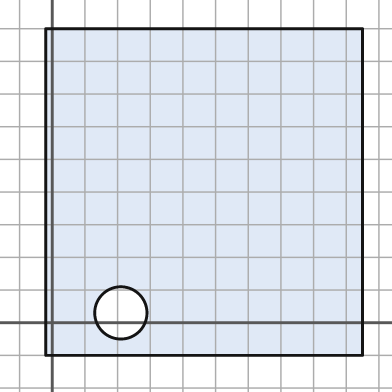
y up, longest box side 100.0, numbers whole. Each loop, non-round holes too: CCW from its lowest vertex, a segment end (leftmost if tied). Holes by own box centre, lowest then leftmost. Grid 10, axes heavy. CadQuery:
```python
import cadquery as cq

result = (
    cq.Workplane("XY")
    .moveTo(-2.0, -10.0)
    .lineTo(95.0, -10.0)
    .lineTo(95.0, 90.0)
    .lineTo(-2.0, 90.0)
    .close()
    .moveTo(21.0, 3.0)
    .circle(8.0)
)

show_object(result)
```